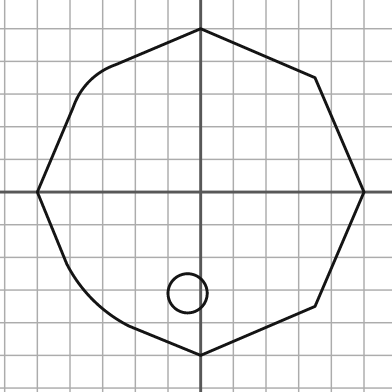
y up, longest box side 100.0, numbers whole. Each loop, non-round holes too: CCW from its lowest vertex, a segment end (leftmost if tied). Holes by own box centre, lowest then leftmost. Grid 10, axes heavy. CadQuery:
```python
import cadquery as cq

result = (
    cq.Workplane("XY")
    .moveTo(0.0, -50.0)
    .lineTo(35.0, -35.0)
    .lineTo(50.0, 0.0)
    .lineTo(35.0, 35.0)
    .lineTo(0.0, 50.0)
    .lineTo(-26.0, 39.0)
    .threePointArc((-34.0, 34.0), (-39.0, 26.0))
    .lineTo(-50.0, 0.0)
    .lineTo(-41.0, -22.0)
    .threePointArc((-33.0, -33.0), (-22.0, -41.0))
    .close()
    .moveTo(-4.0, -31.0)
    .circle(6.0)
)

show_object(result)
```